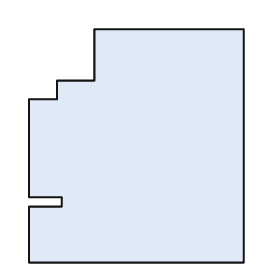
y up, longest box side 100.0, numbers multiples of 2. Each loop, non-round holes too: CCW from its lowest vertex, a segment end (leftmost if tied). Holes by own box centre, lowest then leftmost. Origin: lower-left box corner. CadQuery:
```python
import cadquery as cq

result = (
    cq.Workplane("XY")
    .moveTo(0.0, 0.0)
    .lineTo(92.0, 0.0)
    .lineTo(92.0, 100.0)
    .lineTo(28.0, 100.0)
    .lineTo(28.0, 78.0)
    .lineTo(12.0, 78.0)
    .lineTo(12.0, 70.0)
    .lineTo(0.0, 70.0)
    .lineTo(0.0, 28.0)
    .lineTo(14.0, 28.0)
    .lineTo(14.0, 24.0)
    .lineTo(0.0, 24.0)
    .close()
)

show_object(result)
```